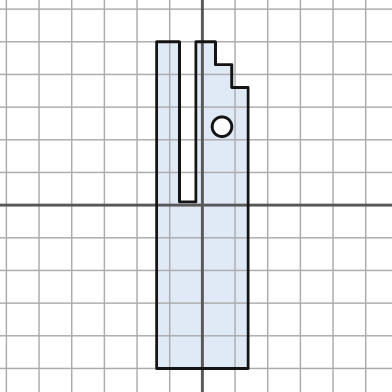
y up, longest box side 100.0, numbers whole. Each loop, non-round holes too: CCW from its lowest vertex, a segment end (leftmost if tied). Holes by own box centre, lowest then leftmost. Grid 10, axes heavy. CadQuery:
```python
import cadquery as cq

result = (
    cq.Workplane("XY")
    .moveTo(-14.0, -50.0)
    .lineTo(14.0, -50.0)
    .lineTo(14.0, 36.0)
    .lineTo(9.0, 36.0)
    .lineTo(9.0, 43.0)
    .lineTo(4.0, 43.0)
    .lineTo(4.0, 50.0)
    .lineTo(-2.0, 50.0)
    .lineTo(-2.0, 1.0)
    .lineTo(-7.0, 1.0)
    .lineTo(-7.0, 50.0)
    .lineTo(-14.0, 50.0)
    .close()
    .moveTo(6.0, 24.0)
    .circle(3.0)
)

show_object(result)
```